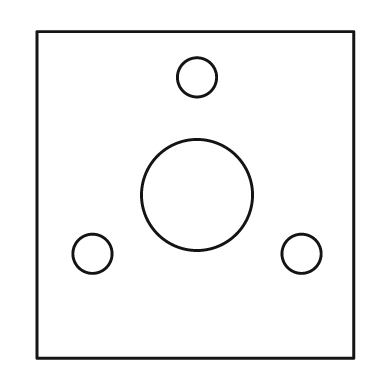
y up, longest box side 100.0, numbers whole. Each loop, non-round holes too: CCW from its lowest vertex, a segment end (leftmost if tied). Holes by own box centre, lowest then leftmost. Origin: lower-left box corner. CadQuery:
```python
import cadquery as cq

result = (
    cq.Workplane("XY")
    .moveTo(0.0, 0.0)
    .lineTo(97.0, 0.0)
    .lineTo(97.0, 100.0)
    .lineTo(0.0, 100.0)
    .close()
    .moveTo(17.0, 32.0)
    .circle(6.0)
    .moveTo(81.0, 32.0)
    .circle(6.0)
    .moveTo(49.0, 50.0)
    .circle(17.0)
    .moveTo(49.0, 86.0)
    .circle(6.0)
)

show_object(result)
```